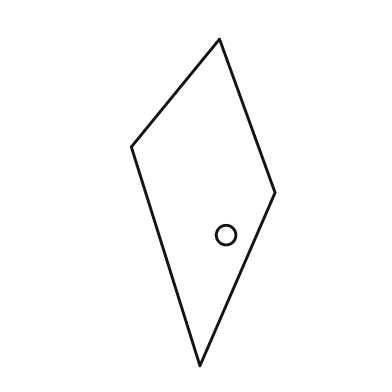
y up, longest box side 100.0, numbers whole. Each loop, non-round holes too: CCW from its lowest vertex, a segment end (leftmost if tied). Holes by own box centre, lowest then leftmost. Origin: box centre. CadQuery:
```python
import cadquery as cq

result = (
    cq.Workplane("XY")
    .moveTo(-1.0, -50.0)
    .lineTo(22.0, 3.0)
    .lineTo(5.0, 50.0)
    .lineTo(-22.0, 17.0)
    .close()
    .moveTo(7.0, -10.0)
    .circle(3.0)
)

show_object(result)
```